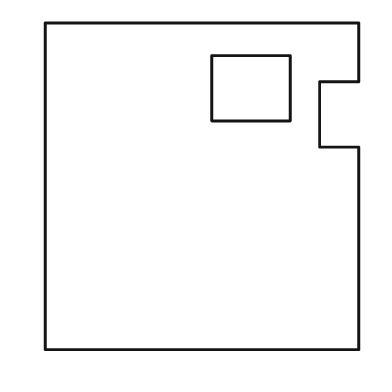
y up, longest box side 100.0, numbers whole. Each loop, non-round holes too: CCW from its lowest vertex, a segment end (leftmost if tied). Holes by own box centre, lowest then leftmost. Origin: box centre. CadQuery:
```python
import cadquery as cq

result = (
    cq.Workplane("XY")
    .moveTo(-48.0, -50.0)
    .lineTo(48.0, -50.0)
    .lineTo(48.0, 12.0)
    .lineTo(36.0, 12.0)
    .lineTo(36.0, 32.0)
    .lineTo(48.0, 32.0)
    .lineTo(48.0, 50.0)
    .lineTo(-48.0, 50.0)
    .close()
    .moveTo(3.0, 20.0)
    .lineTo(27.0, 20.0)
    .lineTo(27.0, 40.0)
    .lineTo(3.0, 40.0)
    .close()
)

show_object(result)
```